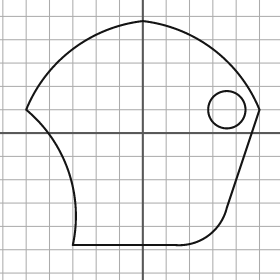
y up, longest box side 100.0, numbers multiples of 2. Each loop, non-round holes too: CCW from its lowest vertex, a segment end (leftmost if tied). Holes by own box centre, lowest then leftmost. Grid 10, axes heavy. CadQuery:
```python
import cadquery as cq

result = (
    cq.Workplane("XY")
    .moveTo(-30.0, -48.0)
    .lineTo(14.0, -48.0)
    .threePointArc((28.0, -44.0), (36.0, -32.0))
    .lineTo(50.0, 10.0)
    .threePointArc((30.0, 36.0), (0.0, 48.0))
    .threePointArc((-30.0, 36.0), (-50.0, 10.0))
    .threePointArc((-32.0, -16.0), (-30.0, -48.0))
    .close()
    .moveTo(36.0, 10.0)
    .circle(8.0)
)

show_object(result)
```